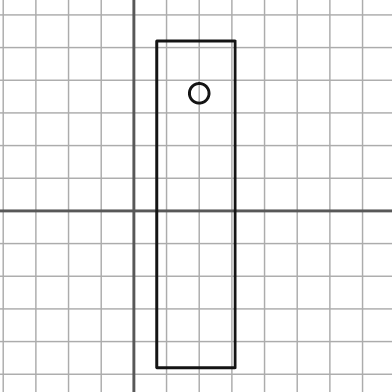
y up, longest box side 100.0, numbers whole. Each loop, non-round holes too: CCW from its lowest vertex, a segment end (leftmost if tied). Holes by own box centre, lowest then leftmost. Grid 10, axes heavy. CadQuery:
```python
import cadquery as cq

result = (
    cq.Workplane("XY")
    .moveTo(7.0, -48.0)
    .lineTo(31.0, -48.0)
    .lineTo(31.0, 52.0)
    .lineTo(7.0, 52.0)
    .close()
    .moveTo(20.0, 36.0)
    .circle(3.0)
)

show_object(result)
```